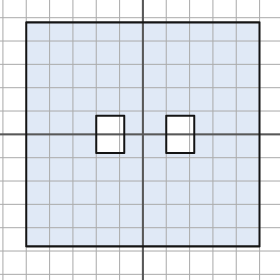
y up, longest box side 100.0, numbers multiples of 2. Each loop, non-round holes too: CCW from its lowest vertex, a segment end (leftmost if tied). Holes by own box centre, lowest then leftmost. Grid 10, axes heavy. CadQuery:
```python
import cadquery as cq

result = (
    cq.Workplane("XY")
    .moveTo(-50.0, -48.0)
    .lineTo(50.0, -48.0)
    .lineTo(50.0, 48.0)
    .lineTo(-50.0, 48.0)
    .close()
    .moveTo(-20.0, -8.0)
    .lineTo(-8.0, -8.0)
    .lineTo(-8.0, 8.0)
    .lineTo(-20.0, 8.0)
    .close()
    .moveTo(10.0, -8.0)
    .lineTo(22.0, -8.0)
    .lineTo(22.0, 8.0)
    .lineTo(10.0, 8.0)
    .close()
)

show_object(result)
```